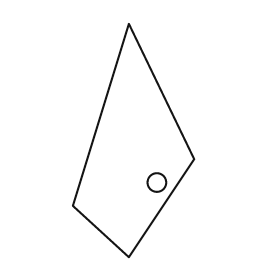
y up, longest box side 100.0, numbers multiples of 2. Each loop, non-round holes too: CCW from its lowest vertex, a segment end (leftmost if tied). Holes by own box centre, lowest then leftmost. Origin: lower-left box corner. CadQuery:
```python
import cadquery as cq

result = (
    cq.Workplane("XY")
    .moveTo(24.0, 0.0)
    .lineTo(52.0, 42.0)
    .lineTo(24.0, 100.0)
    .lineTo(0.0, 22.0)
    .close()
    .moveTo(36.0, 32.0)
    .circle(4.0)
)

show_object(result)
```